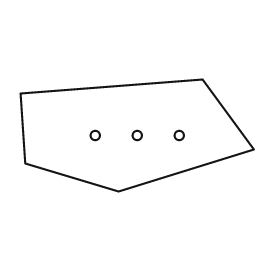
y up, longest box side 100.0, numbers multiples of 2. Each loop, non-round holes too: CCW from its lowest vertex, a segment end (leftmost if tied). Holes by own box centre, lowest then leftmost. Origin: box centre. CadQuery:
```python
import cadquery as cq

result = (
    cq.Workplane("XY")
    .moveTo(-8.0, -24.0)
    .lineTo(50.0, -6.0)
    .lineTo(28.0, 24.0)
    .lineTo(-50.0, 18.0)
    .lineTo(-48.0, -12.0)
    .close()
    .moveTo(-18.0, 0.0)
    .circle(2.0)
    .moveTo(0.0, 0.0)
    .circle(2.0)
    .moveTo(18.0, 0.0)
    .circle(2.0)
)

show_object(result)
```